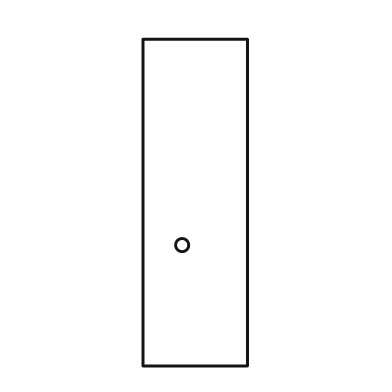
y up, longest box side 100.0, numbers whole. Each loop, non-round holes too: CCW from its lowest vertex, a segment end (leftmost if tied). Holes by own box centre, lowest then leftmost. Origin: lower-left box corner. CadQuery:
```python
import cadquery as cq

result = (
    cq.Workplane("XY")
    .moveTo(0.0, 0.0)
    .lineTo(32.0, 0.0)
    .lineTo(32.0, 100.0)
    .lineTo(0.0, 100.0)
    .close()
    .moveTo(12.0, 37.0)
    .circle(2.0)
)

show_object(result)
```